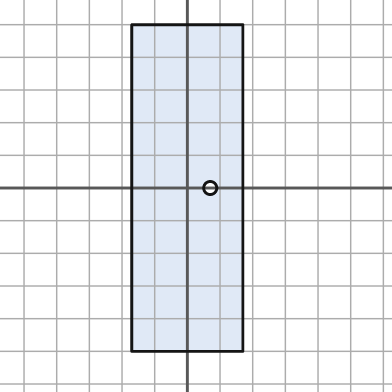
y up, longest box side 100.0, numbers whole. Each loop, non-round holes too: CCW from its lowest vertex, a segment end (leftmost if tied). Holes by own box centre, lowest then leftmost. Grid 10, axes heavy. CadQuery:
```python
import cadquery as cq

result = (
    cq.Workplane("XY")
    .moveTo(-17.0, -50.0)
    .lineTo(17.0, -50.0)
    .lineTo(17.0, 50.0)
    .lineTo(-17.0, 50.0)
    .close()
    .moveTo(7.0, 0.0)
    .circle(2.0)
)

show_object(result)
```